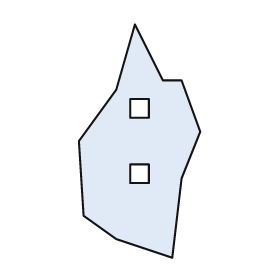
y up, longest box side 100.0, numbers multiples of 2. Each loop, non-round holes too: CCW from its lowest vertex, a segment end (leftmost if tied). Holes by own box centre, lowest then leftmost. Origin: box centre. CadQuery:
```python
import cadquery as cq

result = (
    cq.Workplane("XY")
    .moveTo(14.0, -50.0)
    .lineTo(18.0, -16.0)
    .lineTo(26.0, 4.0)
    .lineTo(18.0, 26.0)
    .lineTo(10.0, 26.0)
    .lineTo(-2.0, 50.0)
    .lineTo(-10.0, 22.0)
    .lineTo(-26.0, 0.0)
    .lineTo(-24.0, -32.0)
    .lineTo(-10.0, -42.0)
    .close()
    .moveTo(-4.0, -18.0)
    .lineTo(4.0, -18.0)
    .lineTo(4.0, -10.0)
    .lineTo(-4.0, -10.0)
    .close()
    .moveTo(-4.0, 10.0)
    .lineTo(4.0, 10.0)
    .lineTo(4.0, 18.0)
    .lineTo(-4.0, 18.0)
    .close()
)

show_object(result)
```